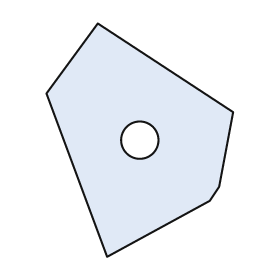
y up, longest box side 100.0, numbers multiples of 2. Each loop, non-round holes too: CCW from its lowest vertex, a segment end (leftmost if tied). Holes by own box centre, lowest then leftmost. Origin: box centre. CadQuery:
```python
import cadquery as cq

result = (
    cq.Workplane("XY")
    .moveTo(-14.0, -50.0)
    .lineTo(30.0, -26.0)
    .lineTo(34.0, -20.0)
    .lineTo(40.0, 12.0)
    .lineTo(-18.0, 50.0)
    .lineTo(-40.0, 20.0)
    .close()
    .moveTo(0.0, 0.0)
    .circle(8.0)
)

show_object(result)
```